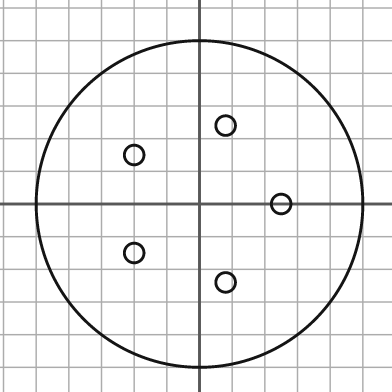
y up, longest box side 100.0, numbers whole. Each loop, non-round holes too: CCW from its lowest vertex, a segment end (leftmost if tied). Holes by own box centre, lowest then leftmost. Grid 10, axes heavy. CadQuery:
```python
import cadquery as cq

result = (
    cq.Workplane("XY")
    .moveTo(0.0, 0.0)
    .circle(50.0)
    .moveTo(8.0, -24.0)
    .circle(3.0)
    .moveTo(-20.0, -15.0)
    .circle(3.0)
    .moveTo(25.0, 0.0)
    .circle(3.0)
    .moveTo(-20.0, 15.0)
    .circle(3.0)
    .moveTo(8.0, 24.0)
    .circle(3.0)
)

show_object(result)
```